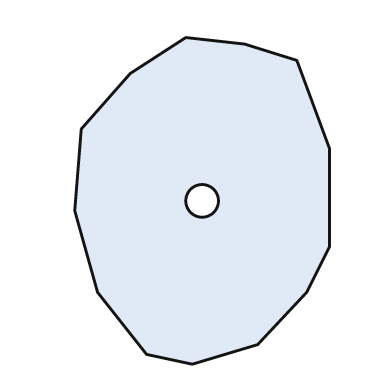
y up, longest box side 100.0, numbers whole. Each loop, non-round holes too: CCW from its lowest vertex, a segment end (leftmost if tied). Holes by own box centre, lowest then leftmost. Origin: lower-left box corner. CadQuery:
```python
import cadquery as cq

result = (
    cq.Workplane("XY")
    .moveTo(36.0, 0.0)
    .lineTo(56.0, 6.0)
    .lineTo(71.0, 22.0)
    .lineTo(78.0, 36.0)
    .lineTo(78.0, 66.0)
    .lineTo(68.0, 93.0)
    .lineTo(52.0, 98.0)
    .lineTo(34.0, 100.0)
    .lineTo(17.0, 89.0)
    .lineTo(2.0, 72.0)
    .lineTo(0.0, 47.0)
    .lineTo(7.0, 22.0)
    .lineTo(22.0, 3.0)
    .close()
    .moveTo(39.0, 50.0)
    .circle(5.0)
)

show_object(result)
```